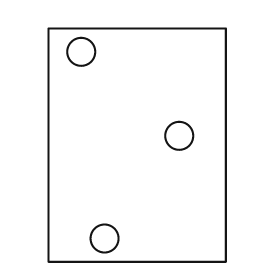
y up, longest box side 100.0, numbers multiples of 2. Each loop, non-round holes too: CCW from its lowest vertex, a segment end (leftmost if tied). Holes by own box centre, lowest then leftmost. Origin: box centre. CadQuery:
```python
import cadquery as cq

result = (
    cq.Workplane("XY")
    .moveTo(-38.0, -50.0)
    .lineTo(38.0, -50.0)
    .lineTo(38.0, 50.0)
    .lineTo(-38.0, 50.0)
    .close()
    .moveTo(-14.0, -40.0)
    .circle(6.0)
    .moveTo(18.0, 4.0)
    .circle(6.0)
    .moveTo(-24.0, 40.0)
    .circle(6.0)
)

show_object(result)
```